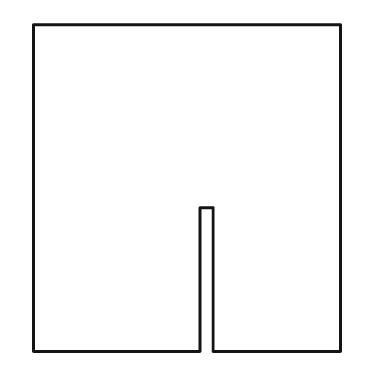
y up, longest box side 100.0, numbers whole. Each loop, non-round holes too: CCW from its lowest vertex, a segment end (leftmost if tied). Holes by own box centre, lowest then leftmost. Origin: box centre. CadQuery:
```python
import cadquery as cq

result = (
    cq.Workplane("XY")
    .moveTo(-47.0, -50.0)
    .lineTo(4.0, -50.0)
    .lineTo(4.0, -6.0)
    .lineTo(8.0, -6.0)
    .lineTo(8.0, -50.0)
    .lineTo(47.0, -50.0)
    .lineTo(47.0, 50.0)
    .lineTo(-47.0, 50.0)
    .close()
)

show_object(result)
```